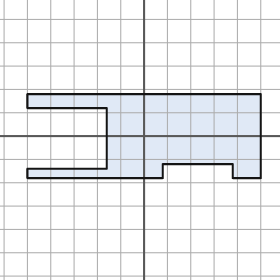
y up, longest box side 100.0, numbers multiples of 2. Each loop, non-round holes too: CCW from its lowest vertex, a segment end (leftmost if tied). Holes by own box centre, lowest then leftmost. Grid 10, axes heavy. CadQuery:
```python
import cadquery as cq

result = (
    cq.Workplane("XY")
    .moveTo(-50.0, -18.0)
    .lineTo(8.0, -18.0)
    .lineTo(8.0, -12.0)
    .lineTo(38.0, -12.0)
    .lineTo(38.0, -18.0)
    .lineTo(50.0, -18.0)
    .lineTo(50.0, 18.0)
    .lineTo(-50.0, 18.0)
    .lineTo(-50.0, 12.0)
    .lineTo(-16.0, 12.0)
    .lineTo(-16.0, -14.0)
    .lineTo(-50.0, -14.0)
    .close()
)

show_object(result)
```